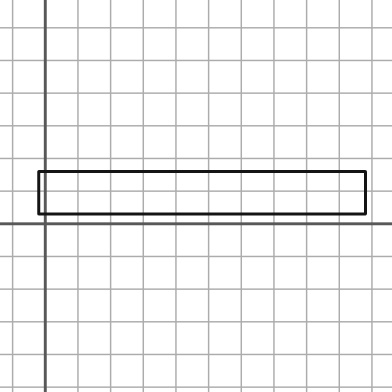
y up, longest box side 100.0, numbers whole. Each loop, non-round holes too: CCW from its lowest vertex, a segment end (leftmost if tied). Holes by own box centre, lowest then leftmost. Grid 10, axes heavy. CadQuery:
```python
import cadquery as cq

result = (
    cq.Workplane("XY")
    .moveTo(-2.0, 3.0)
    .lineTo(98.0, 3.0)
    .lineTo(98.0, 16.0)
    .lineTo(-2.0, 16.0)
    .close()
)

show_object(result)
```